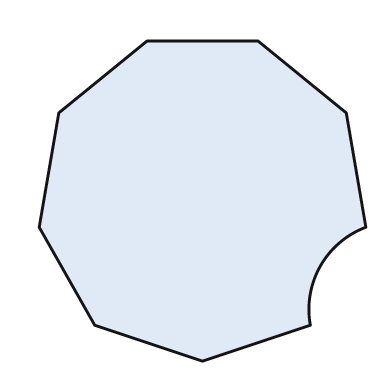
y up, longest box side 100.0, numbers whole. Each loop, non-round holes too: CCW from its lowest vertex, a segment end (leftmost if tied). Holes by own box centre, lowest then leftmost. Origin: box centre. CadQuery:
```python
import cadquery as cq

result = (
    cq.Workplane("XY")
    .moveTo(0.0, -49.0)
    .lineTo(33.0, -38.0)
    .threePointArc((36.0, -20.0), (50.0, -8.0))
    .lineTo(44.0, 27.0)
    .lineTo(17.0, 49.0)
    .lineTo(-17.0, 49.0)
    .lineTo(-44.0, 27.0)
    .lineTo(-50.0, -8.0)
    .lineTo(-33.0, -38.0)
    .close()
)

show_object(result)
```